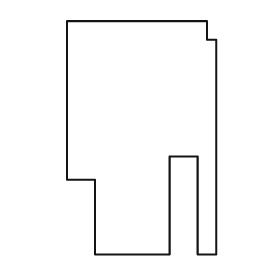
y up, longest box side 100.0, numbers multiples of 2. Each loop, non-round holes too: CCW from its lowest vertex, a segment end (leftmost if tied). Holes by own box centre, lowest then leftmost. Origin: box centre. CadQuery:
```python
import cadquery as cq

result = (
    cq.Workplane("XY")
    .moveTo(-20.0, -50.0)
    .lineTo(12.0, -50.0)
    .lineTo(12.0, -8.0)
    .lineTo(24.0, -8.0)
    .lineTo(24.0, -50.0)
    .lineTo(32.0, -50.0)
    .lineTo(32.0, 42.0)
    .lineTo(28.0, 42.0)
    .lineTo(28.0, 50.0)
    .lineTo(-32.0, 50.0)
    .lineTo(-32.0, -18.0)
    .lineTo(-20.0, -18.0)
    .close()
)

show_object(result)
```